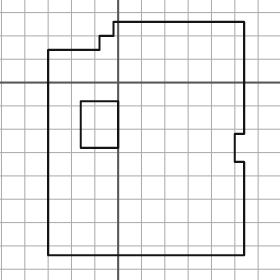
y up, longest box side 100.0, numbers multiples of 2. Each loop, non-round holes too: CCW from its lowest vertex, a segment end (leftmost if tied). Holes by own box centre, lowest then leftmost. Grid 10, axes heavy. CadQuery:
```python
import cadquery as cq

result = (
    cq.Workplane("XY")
    .moveTo(-30.0, -74.0)
    .lineTo(54.0, -74.0)
    .lineTo(54.0, -34.0)
    .lineTo(50.0, -34.0)
    .lineTo(50.0, -22.0)
    .lineTo(54.0, -22.0)
    .lineTo(54.0, 26.0)
    .lineTo(-2.0, 26.0)
    .lineTo(-2.0, 20.0)
    .lineTo(-8.0, 20.0)
    .lineTo(-8.0, 14.0)
    .lineTo(-30.0, 14.0)
    .close()
    .moveTo(-16.0, -28.0)
    .lineTo(0.0, -28.0)
    .lineTo(0.0, -8.0)
    .lineTo(-16.0, -8.0)
    .close()
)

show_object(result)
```